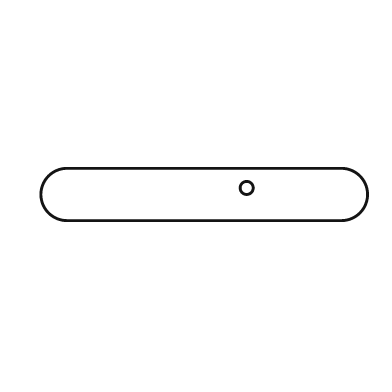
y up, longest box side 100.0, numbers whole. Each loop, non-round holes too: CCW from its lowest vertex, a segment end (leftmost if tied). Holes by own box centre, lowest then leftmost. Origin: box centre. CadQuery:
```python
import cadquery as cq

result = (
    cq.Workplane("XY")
    .moveTo(-42.0, -8.0)
    .lineTo(42.0, -8.0)
    .threePointArc((50.0, 0.0), (42.0, 8.0))
    .lineTo(-42.0, 8.0)
    .threePointArc((-50.0, 0.0), (-42.0, -8.0))
    .close()
    .moveTo(13.0, 2.0)
    .circle(2.0)
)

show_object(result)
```